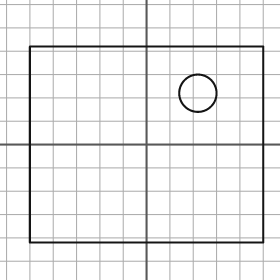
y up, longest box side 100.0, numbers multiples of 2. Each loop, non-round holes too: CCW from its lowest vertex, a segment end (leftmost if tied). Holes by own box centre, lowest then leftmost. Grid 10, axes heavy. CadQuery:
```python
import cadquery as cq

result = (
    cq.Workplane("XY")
    .moveTo(-50.0, -42.0)
    .lineTo(50.0, -42.0)
    .lineTo(50.0, 42.0)
    .lineTo(-50.0, 42.0)
    .close()
    .moveTo(22.0, 22.0)
    .circle(8.0)
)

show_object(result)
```